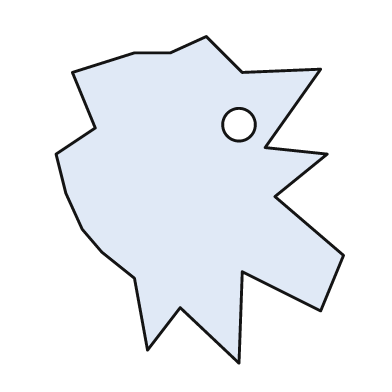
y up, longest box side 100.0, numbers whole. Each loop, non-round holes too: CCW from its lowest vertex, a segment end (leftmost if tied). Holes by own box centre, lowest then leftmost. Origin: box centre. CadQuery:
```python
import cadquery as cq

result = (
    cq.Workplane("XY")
    .moveTo(12.0, -50.0)
    .lineTo(13.0, -22.0)
    .lineTo(37.0, -34.0)
    .lineTo(44.0, -17.0)
    .lineTo(23.0, 1.0)
    .lineTo(39.0, 14.0)
    .lineTo(20.0, 16.0)
    .lineTo(37.0, 40.0)
    .lineTo(13.0, 39.0)
    .lineTo(2.0, 50.0)
    .lineTo(-9.0, 45.0)
    .lineTo(-20.0, 45.0)
    .lineTo(-39.0, 39.0)
    .lineTo(-32.0, 22.0)
    .lineTo(-44.0, 14.0)
    .lineTo(-41.0, 2.0)
    .lineTo(-36.0, -9.0)
    .lineTo(-30.0, -16.0)
    .lineTo(-20.0, -24.0)
    .lineTo(-16.0, -46.0)
    .lineTo(-6.0, -33.0)
    .close()
    .moveTo(12.0, 23.0)
    .circle(5.0)
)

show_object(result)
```